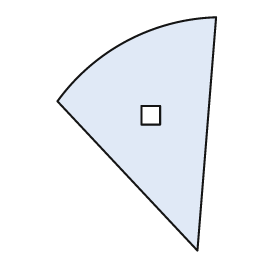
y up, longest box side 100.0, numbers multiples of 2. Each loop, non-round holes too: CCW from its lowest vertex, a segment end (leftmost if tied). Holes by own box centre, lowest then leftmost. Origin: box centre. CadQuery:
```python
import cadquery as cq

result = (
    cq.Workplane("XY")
    .moveTo(26.0, -50.0)
    .lineTo(34.0, 50.0)
    .threePointArc((-4.0, 40.0), (-34.0, 14.0))
    .close()
    .moveTo(2.0, 4.0)
    .lineTo(10.0, 4.0)
    .lineTo(10.0, 12.0)
    .lineTo(2.0, 12.0)
    .close()
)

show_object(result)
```